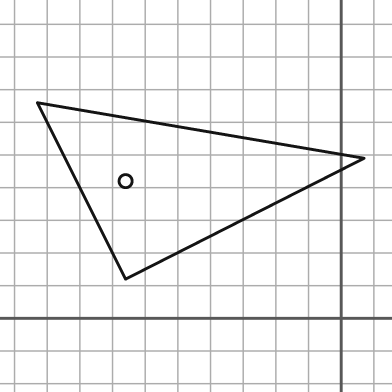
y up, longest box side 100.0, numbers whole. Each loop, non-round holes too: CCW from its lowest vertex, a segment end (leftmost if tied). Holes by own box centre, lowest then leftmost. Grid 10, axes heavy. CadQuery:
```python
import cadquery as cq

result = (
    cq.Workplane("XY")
    .moveTo(-66.0, 12.0)
    .lineTo(7.0, 49.0)
    .lineTo(-93.0, 66.0)
    .close()
    .moveTo(-66.0, 42.0)
    .circle(2.0)
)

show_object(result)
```